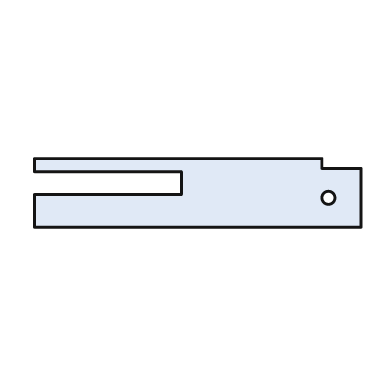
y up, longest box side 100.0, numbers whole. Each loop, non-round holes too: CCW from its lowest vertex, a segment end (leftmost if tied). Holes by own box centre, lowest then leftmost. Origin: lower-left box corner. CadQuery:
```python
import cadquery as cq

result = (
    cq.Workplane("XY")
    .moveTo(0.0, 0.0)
    .lineTo(100.0, 0.0)
    .lineTo(100.0, 18.0)
    .lineTo(88.0, 18.0)
    .lineTo(88.0, 21.0)
    .lineTo(0.0, 21.0)
    .lineTo(0.0, 17.0)
    .lineTo(45.0, 17.0)
    .lineTo(45.0, 10.0)
    .lineTo(0.0, 10.0)
    .close()
    .moveTo(90.0, 9.0)
    .circle(2.0)
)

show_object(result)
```